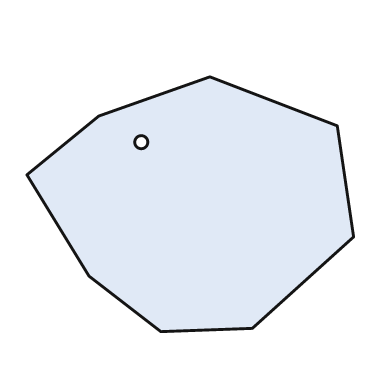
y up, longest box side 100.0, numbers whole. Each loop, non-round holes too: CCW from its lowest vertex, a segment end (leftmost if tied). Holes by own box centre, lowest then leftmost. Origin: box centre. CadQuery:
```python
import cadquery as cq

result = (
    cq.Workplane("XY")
    .moveTo(-9.0, -39.0)
    .lineTo(19.0, -38.0)
    .lineTo(50.0, -10.0)
    .lineTo(45.0, 24.0)
    .lineTo(6.0, 39.0)
    .lineTo(-28.0, 27.0)
    .lineTo(-50.0, 9.0)
    .lineTo(-31.0, -22.0)
    .close()
    .moveTo(-15.0, 19.0)
    .circle(2.0)
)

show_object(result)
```